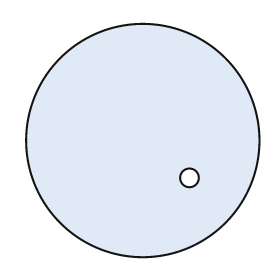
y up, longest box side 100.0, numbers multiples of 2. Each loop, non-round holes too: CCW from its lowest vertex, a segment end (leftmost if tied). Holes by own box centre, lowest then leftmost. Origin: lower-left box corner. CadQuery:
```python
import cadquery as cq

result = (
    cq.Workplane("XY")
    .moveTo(50.0, 50.0)
    .circle(50.0)
    .moveTo(70.0, 34.0)
    .circle(4.0)
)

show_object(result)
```